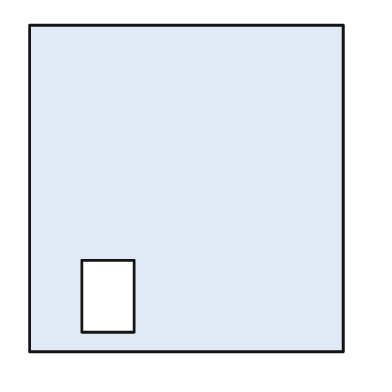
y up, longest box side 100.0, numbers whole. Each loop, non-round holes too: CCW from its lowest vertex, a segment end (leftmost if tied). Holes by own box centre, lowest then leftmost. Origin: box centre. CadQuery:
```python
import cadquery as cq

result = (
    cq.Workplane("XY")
    .moveTo(-48.0, -50.0)
    .lineTo(48.0, -50.0)
    .lineTo(48.0, 50.0)
    .lineTo(-48.0, 50.0)
    .close()
    .moveTo(-32.0, -44.0)
    .lineTo(-16.0, -44.0)
    .lineTo(-16.0, -22.0)
    .lineTo(-32.0, -22.0)
    .close()
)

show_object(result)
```